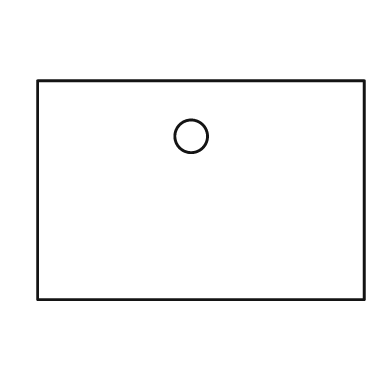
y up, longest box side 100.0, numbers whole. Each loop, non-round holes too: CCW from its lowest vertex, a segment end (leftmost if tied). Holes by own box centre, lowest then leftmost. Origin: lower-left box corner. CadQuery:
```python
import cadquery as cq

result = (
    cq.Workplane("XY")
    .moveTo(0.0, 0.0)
    .lineTo(100.0, 0.0)
    .lineTo(100.0, 67.0)
    .lineTo(0.0, 67.0)
    .close()
    .moveTo(47.0, 50.0)
    .circle(5.0)
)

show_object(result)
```